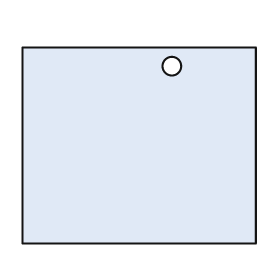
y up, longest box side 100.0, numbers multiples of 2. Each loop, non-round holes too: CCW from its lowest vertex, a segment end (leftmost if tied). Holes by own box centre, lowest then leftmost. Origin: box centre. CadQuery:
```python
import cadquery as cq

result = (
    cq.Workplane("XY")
    .moveTo(-50.0, -42.0)
    .lineTo(50.0, -42.0)
    .lineTo(50.0, 42.0)
    .lineTo(-50.0, 42.0)
    .close()
    .moveTo(14.0, 34.0)
    .circle(4.0)
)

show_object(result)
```